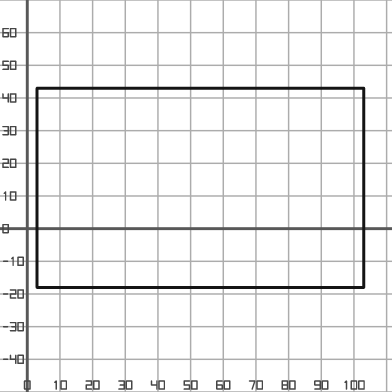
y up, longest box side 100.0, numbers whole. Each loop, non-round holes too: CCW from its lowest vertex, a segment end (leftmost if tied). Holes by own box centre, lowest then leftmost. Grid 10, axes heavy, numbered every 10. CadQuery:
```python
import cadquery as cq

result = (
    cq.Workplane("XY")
    .moveTo(3.0, -18.0)
    .lineTo(103.0, -18.0)
    .lineTo(103.0, 43.0)
    .lineTo(3.0, 43.0)
    .close()
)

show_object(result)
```